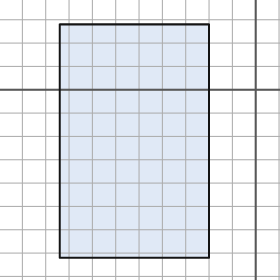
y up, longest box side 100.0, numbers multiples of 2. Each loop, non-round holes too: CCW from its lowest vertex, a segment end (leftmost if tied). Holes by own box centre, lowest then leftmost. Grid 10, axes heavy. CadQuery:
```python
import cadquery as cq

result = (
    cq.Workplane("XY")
    .moveTo(-84.0, -72.0)
    .lineTo(-20.0, -72.0)
    .lineTo(-20.0, 28.0)
    .lineTo(-84.0, 28.0)
    .close()
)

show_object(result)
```